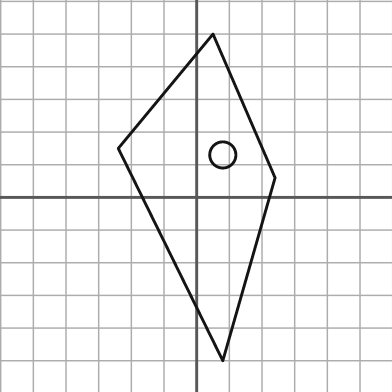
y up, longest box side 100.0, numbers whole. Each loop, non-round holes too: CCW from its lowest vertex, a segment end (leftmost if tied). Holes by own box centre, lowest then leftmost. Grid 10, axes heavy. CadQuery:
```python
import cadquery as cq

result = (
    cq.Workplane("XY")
    .moveTo(8.0, -50.0)
    .lineTo(24.0, 6.0)
    .lineTo(5.0, 50.0)
    .lineTo(-24.0, 15.0)
    .close()
    .moveTo(8.0, 13.0)
    .circle(4.0)
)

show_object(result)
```